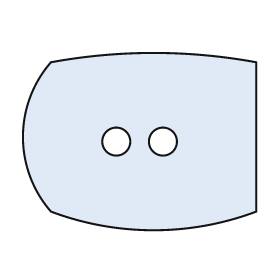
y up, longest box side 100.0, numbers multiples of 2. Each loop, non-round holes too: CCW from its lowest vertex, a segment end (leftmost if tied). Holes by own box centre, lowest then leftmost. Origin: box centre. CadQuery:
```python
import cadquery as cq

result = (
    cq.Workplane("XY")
    .moveTo(-38.0, -30.0)
    .threePointArc((6.0, -38.0), (50.0, -30.0))
    .lineTo(50.0, 34.0)
    .threePointArc((6.0, 38.0), (-38.0, 34.0))
    .threePointArc((-50.0, 2.0), (-38.0, -30.0))
    .close()
    .moveTo(-10.0, 0.0)
    .circle(6.0)
    .moveTo(10.0, 0.0)
    .circle(6.0)
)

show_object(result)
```